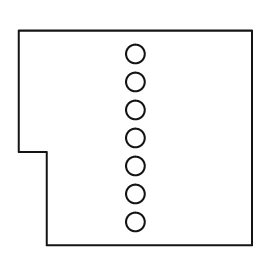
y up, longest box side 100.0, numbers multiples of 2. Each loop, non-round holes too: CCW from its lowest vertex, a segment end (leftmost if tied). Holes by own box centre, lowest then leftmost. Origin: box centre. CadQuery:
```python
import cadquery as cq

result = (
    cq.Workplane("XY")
    .moveTo(-38.0, -46.0)
    .lineTo(50.0, -46.0)
    .lineTo(50.0, 46.0)
    .lineTo(-50.0, 46.0)
    .lineTo(-50.0, -6.0)
    .lineTo(-38.0, -6.0)
    .close()
    .moveTo(0.0, -36.0)
    .circle(4.0)
    .moveTo(0.0, -24.0)
    .circle(4.0)
    .moveTo(0.0, -12.0)
    .circle(4.0)
    .moveTo(0.0, 0.0)
    .circle(4.0)
    .moveTo(0.0, 12.0)
    .circle(4.0)
    .moveTo(0.0, 24.0)
    .circle(4.0)
    .moveTo(0.0, 36.0)
    .circle(4.0)
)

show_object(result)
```